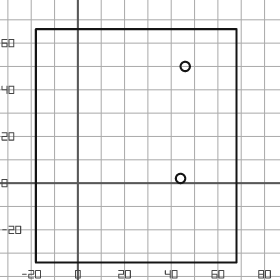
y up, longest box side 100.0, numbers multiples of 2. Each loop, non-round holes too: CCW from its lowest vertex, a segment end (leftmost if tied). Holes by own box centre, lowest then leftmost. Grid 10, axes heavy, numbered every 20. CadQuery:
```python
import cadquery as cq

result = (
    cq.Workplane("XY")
    .moveTo(-18.0, -34.0)
    .lineTo(68.0, -34.0)
    .lineTo(68.0, 66.0)
    .lineTo(-18.0, 66.0)
    .close()
    .moveTo(44.0, 2.0)
    .circle(2.0)
    .moveTo(46.0, 50.0)
    .circle(2.0)
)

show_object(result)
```